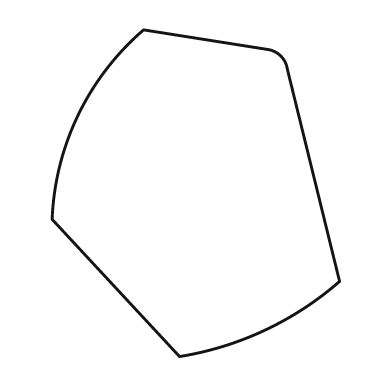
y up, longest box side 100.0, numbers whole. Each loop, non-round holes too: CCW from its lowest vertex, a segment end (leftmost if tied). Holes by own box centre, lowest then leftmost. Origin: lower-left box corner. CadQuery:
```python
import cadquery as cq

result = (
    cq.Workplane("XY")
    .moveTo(39.0, 0.0)
    .threePointArc((65.0, 8.0), (88.0, 23.0))
    .lineTo(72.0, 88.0)
    .threePointArc((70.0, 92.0), (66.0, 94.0))
    .lineTo(28.0, 100.0)
    .threePointArc((8.0, 74.0), (0.0, 42.0))
    .close()
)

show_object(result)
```